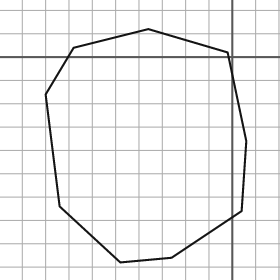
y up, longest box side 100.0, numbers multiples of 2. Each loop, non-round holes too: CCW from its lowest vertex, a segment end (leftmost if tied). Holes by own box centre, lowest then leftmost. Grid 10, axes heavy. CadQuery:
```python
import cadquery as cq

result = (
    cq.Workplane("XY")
    .moveTo(-48.0, -88.0)
    .lineTo(-26.0, -86.0)
    .lineTo(4.0, -66.0)
    .lineTo(6.0, -36.0)
    .lineTo(-2.0, 2.0)
    .lineTo(-36.0, 12.0)
    .lineTo(-68.0, 4.0)
    .lineTo(-80.0, -16.0)
    .lineTo(-74.0, -64.0)
    .close()
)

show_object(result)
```